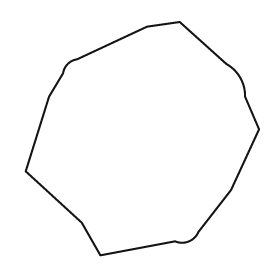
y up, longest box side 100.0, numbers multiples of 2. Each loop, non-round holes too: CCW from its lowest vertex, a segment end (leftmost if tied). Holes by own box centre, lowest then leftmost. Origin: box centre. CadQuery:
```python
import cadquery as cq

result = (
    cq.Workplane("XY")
    .moveTo(-18.0, -50.0)
    .lineTo(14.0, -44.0)
    .threePointArc((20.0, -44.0), (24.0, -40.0))
    .lineTo(38.0, -22.0)
    .lineTo(50.0, 4.0)
    .lineTo(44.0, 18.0)
    .threePointArc((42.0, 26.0), (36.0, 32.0))
    .lineTo(16.0, 50.0)
    .lineTo(2.0, 48.0)
    .lineTo(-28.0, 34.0)
    .threePointArc((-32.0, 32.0), (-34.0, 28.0))
    .lineTo(-40.0, 18.0)
    .lineTo(-50.0, -14.0)
    .lineTo(-26.0, -36.0)
    .close()
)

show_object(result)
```